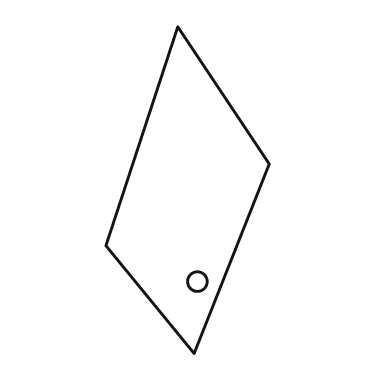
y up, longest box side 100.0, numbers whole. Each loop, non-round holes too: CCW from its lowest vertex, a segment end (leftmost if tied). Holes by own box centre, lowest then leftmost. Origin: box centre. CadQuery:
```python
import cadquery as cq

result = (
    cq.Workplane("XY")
    .moveTo(2.0, -50.0)
    .lineTo(25.0, 8.0)
    .lineTo(-3.0, 50.0)
    .lineTo(-25.0, -17.0)
    .close()
    .moveTo(3.0, -28.0)
    .circle(3.0)
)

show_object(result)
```